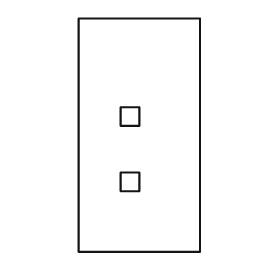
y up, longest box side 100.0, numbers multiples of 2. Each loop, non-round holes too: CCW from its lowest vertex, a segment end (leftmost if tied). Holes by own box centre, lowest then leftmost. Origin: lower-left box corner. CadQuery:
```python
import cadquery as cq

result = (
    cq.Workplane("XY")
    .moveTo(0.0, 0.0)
    .lineTo(52.0, 0.0)
    .lineTo(52.0, 100.0)
    .lineTo(0.0, 100.0)
    .close()
    .moveTo(18.0, 26.0)
    .lineTo(26.0, 26.0)
    .lineTo(26.0, 34.0)
    .lineTo(18.0, 34.0)
    .close()
    .moveTo(18.0, 54.0)
    .lineTo(26.0, 54.0)
    .lineTo(26.0, 62.0)
    .lineTo(18.0, 62.0)
    .close()
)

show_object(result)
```